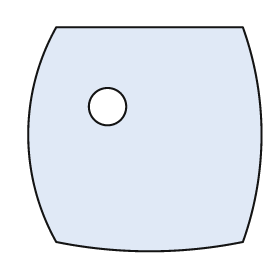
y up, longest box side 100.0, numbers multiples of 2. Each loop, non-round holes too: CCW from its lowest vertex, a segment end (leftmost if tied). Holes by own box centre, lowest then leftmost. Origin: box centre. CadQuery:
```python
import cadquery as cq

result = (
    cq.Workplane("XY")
    .moveTo(-38.0, -44.0)
    .threePointArc((2.0, -48.0), (42.0, -44.0))
    .threePointArc((50.0, 2.0), (42.0, 48.0))
    .lineTo(-38.0, 48.0)
    .threePointArc((-50.0, 2.0), (-38.0, -44.0))
    .close()
    .moveTo(-16.0, 14.0)
    .circle(8.0)
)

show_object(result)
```